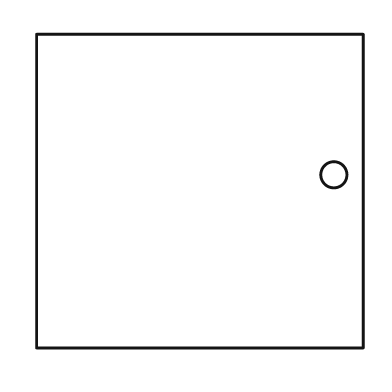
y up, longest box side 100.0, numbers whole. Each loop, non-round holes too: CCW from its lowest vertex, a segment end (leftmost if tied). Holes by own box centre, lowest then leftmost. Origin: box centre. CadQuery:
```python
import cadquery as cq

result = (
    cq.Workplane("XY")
    .moveTo(-50.0, -48.0)
    .lineTo(50.0, -48.0)
    .lineTo(50.0, 48.0)
    .lineTo(-50.0, 48.0)
    .close()
    .moveTo(41.0, 5.0)
    .circle(4.0)
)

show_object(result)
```